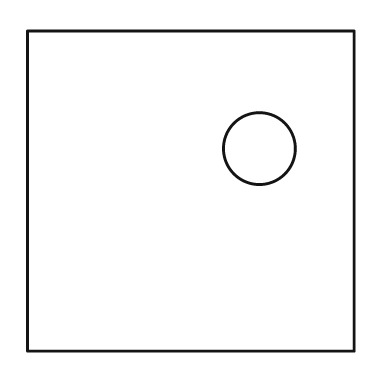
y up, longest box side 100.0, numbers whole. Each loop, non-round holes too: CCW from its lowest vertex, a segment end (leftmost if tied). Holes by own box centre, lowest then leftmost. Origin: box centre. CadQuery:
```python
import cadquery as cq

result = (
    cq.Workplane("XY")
    .moveTo(-50.0, -49.0)
    .lineTo(50.0, -49.0)
    .lineTo(50.0, 49.0)
    .lineTo(-50.0, 49.0)
    .close()
    .moveTo(21.0, 13.0)
    .circle(11.0)
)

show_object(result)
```